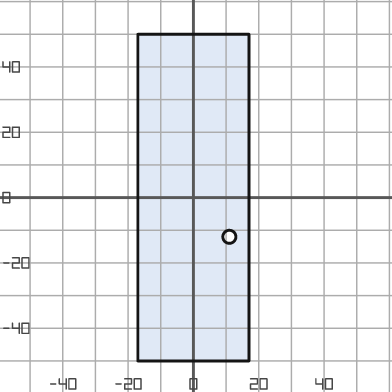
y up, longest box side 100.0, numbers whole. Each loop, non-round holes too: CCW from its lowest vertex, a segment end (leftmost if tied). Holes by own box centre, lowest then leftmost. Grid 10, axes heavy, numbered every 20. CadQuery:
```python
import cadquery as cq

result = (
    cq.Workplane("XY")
    .moveTo(-17.0, -50.0)
    .lineTo(17.0, -50.0)
    .lineTo(17.0, 50.0)
    .lineTo(-17.0, 50.0)
    .close()
    .moveTo(11.0, -12.0)
    .circle(2.0)
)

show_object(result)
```